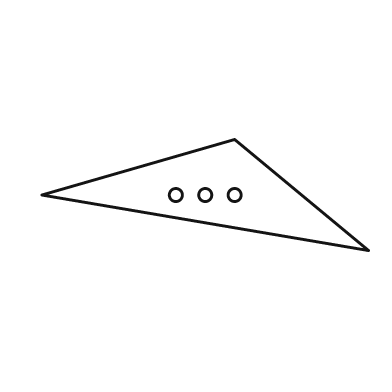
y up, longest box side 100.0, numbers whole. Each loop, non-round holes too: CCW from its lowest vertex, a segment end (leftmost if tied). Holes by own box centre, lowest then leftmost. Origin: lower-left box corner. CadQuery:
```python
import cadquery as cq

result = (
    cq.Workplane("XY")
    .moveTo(100.0, 0.0)
    .lineTo(59.0, 34.0)
    .lineTo(0.0, 17.0)
    .close()
    .moveTo(41.0, 17.0)
    .circle(2.0)
    .moveTo(50.0, 17.0)
    .circle(2.0)
    .moveTo(59.0, 17.0)
    .circle(2.0)
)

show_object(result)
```